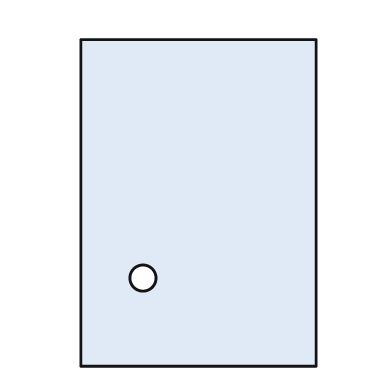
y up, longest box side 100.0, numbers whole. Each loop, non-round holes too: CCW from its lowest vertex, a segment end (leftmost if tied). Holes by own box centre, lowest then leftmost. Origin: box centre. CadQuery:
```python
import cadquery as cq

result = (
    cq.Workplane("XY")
    .moveTo(-36.0, -50.0)
    .lineTo(36.0, -50.0)
    .lineTo(36.0, 50.0)
    .lineTo(-36.0, 50.0)
    .close()
    .moveTo(-17.0, -23.0)
    .circle(4.0)
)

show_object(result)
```